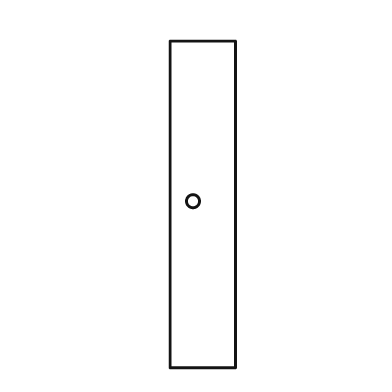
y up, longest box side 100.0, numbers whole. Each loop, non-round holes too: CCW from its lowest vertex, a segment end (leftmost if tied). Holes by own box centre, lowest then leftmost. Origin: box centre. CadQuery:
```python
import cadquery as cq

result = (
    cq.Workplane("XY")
    .moveTo(-10.0, -50.0)
    .lineTo(10.0, -50.0)
    .lineTo(10.0, 50.0)
    .lineTo(-10.0, 50.0)
    .close()
    .moveTo(-3.0, 1.0)
    .circle(2.0)
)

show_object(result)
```